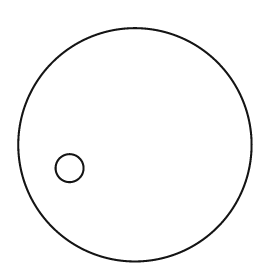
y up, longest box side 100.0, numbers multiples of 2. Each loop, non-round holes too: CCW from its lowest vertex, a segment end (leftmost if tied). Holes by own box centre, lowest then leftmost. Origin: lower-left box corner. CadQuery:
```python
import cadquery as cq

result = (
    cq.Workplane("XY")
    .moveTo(50.0, 50.0)
    .circle(50.0)
    .moveTo(22.0, 40.0)
    .circle(6.0)
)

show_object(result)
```